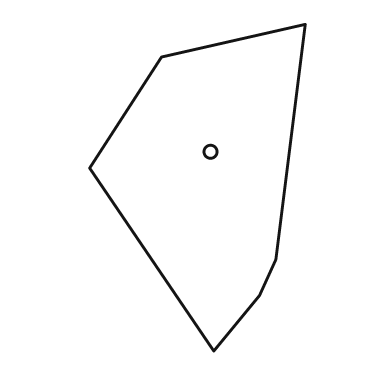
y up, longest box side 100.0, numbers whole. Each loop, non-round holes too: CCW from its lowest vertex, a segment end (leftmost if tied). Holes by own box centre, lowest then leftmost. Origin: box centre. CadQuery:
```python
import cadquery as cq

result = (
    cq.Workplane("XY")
    .moveTo(5.0, -50.0)
    .lineTo(19.0, -33.0)
    .lineTo(24.0, -22.0)
    .lineTo(33.0, 50.0)
    .lineTo(-11.0, 40.0)
    .lineTo(-33.0, 6.0)
    .close()
    .moveTo(4.0, 11.0)
    .circle(2.0)
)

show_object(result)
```